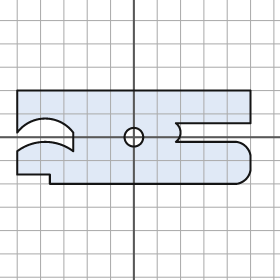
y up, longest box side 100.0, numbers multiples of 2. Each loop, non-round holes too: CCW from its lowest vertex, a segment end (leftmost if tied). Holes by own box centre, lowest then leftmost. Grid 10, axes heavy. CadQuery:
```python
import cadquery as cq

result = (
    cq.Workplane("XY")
    .moveTo(-36.0, -20.0)
    .lineTo(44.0, -20.0)
    .threePointArc((48.0, -18.0), (50.0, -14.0))
    .lineTo(50.0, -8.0)
    .threePointArc((48.0, -4.0), (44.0, -2.0))
    .lineTo(18.0, -2.0)
    .threePointArc((20.0, 2.0), (18.0, 6.0))
    .lineTo(50.0, 6.0)
    .lineTo(50.0, 20.0)
    .lineTo(-50.0, 20.0)
    .lineTo(-50.0, 2.0)
    .threePointArc((-38.0, 8.0), (-26.0, 2.0))
    .lineTo(-26.0, -6.0)
    .threePointArc((-38.0, -2.0), (-50.0, -6.0))
    .lineTo(-50.0, -16.0)
    .lineTo(-36.0, -16.0)
    .close()
    .moveTo(0.0, 0.0)
    .circle(4.0)
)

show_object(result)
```